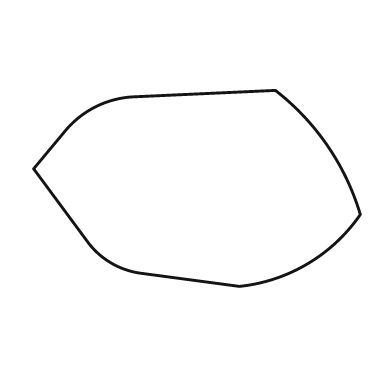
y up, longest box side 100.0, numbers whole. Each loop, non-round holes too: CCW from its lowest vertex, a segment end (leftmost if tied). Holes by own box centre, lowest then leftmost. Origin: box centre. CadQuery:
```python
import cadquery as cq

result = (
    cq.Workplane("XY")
    .moveTo(13.0, -30.0)
    .threePointArc((34.0, -23.0), (50.0, -8.0))
    .threePointArc((40.0, 13.0), (24.0, 30.0))
    .lineTo(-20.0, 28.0)
    .threePointArc((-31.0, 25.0), (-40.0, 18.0))
    .lineTo(-50.0, 6.0)
    .lineTo(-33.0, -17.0)
    .threePointArc((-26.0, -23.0), (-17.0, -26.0))
    .close()
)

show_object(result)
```